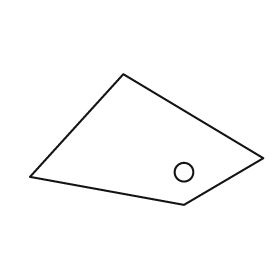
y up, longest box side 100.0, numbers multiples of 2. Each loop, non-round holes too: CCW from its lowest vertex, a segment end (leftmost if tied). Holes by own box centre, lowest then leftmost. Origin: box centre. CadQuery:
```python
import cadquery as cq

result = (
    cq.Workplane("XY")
    .moveTo(16.0, -28.0)
    .lineTo(50.0, -8.0)
    .lineTo(-10.0, 28.0)
    .lineTo(-50.0, -16.0)
    .close()
    .moveTo(16.0, -14.0)
    .circle(4.0)
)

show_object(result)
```